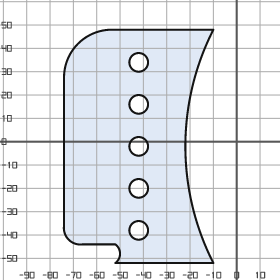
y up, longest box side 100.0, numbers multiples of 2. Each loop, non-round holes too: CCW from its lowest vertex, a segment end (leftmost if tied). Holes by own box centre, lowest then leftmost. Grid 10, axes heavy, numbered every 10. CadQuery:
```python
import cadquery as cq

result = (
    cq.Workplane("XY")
    .moveTo(-52.0, -52.0)
    .lineTo(-10.0, -52.0)
    .threePointArc((-22.0, -2.0), (-10.0, 48.0))
    .lineTo(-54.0, 48.0)
    .threePointArc((-68.0, 42.0), (-74.0, 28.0))
    .lineTo(-74.0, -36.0)
    .threePointArc((-72.0, -42.0), (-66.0, -44.0))
    .lineTo(-52.0, -44.0)
    .threePointArc((-50.0, -48.0), (-52.0, -52.0))
    .close()
    .moveTo(-42.0, -38.0)
    .circle(4.0)
    .moveTo(-42.0, -20.0)
    .circle(4.0)
    .moveTo(-42.0, -2.0)
    .circle(4.0)
    .moveTo(-42.0, 16.0)
    .circle(4.0)
    .moveTo(-42.0, 34.0)
    .circle(4.0)
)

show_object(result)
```